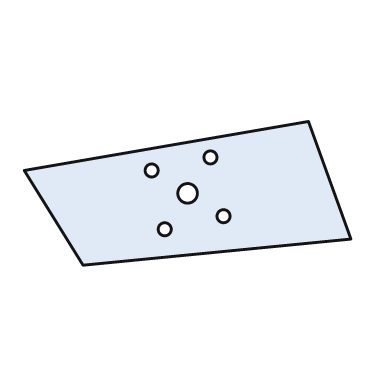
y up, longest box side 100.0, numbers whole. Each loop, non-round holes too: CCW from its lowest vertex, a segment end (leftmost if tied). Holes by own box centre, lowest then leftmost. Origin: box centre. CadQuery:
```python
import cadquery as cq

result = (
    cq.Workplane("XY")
    .moveTo(-32.0, -22.0)
    .lineTo(50.0, -14.0)
    .lineTo(37.0, 22.0)
    .lineTo(-50.0, 7.0)
    .close()
    .moveTo(-7.0, -11.0)
    .circle(2.0)
    .moveTo(11.0, -7.0)
    .circle(2.0)
    .moveTo(0.0, 0.0)
    .circle(3.0)
    .moveTo(-11.0, 7.0)
    .circle(2.0)
    .moveTo(7.0, 11.0)
    .circle(2.0)
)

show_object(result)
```